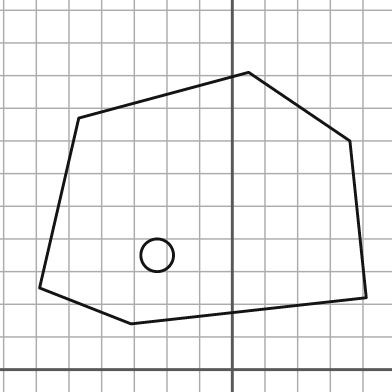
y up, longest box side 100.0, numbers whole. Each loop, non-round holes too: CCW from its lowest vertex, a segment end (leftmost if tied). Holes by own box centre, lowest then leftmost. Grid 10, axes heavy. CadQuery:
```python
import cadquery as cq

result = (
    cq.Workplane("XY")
    .moveTo(-31.0, 14.0)
    .lineTo(41.0, 22.0)
    .lineTo(36.0, 70.0)
    .lineTo(5.0, 91.0)
    .lineTo(-47.0, 77.0)
    .lineTo(-59.0, 25.0)
    .close()
    .moveTo(-23.0, 35.0)
    .circle(5.0)
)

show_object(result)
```